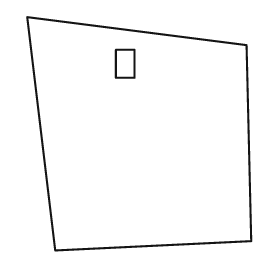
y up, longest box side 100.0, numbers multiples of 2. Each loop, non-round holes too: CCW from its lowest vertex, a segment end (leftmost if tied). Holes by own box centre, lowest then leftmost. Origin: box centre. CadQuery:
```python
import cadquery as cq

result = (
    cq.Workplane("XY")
    .moveTo(-36.0, -50.0)
    .lineTo(48.0, -46.0)
    .lineTo(46.0, 38.0)
    .lineTo(-48.0, 50.0)
    .close()
    .moveTo(-10.0, 24.0)
    .lineTo(-2.0, 24.0)
    .lineTo(-2.0, 36.0)
    .lineTo(-10.0, 36.0)
    .close()
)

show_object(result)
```